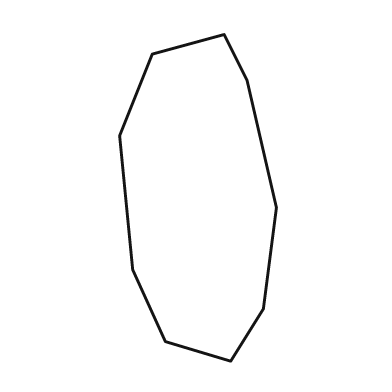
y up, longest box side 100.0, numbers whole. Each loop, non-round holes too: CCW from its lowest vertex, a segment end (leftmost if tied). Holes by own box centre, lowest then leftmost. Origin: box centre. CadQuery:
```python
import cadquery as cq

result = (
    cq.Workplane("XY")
    .moveTo(10.0, -50.0)
    .lineTo(20.0, -34.0)
    .lineTo(24.0, -3.0)
    .lineTo(15.0, 36.0)
    .lineTo(8.0, 50.0)
    .lineTo(-14.0, 44.0)
    .lineTo(-24.0, 19.0)
    .lineTo(-20.0, -22.0)
    .lineTo(-10.0, -44.0)
    .close()
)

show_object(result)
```